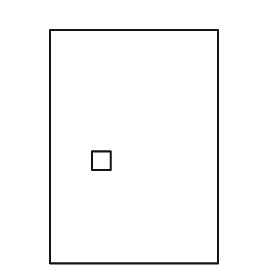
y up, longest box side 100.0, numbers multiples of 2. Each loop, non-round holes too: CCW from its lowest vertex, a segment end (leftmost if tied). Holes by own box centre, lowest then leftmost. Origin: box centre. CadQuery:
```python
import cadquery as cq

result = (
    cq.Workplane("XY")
    .moveTo(-36.0, -50.0)
    .lineTo(36.0, -50.0)
    .lineTo(36.0, 50.0)
    .lineTo(-36.0, 50.0)
    .close()
    .moveTo(-18.0, -10.0)
    .lineTo(-10.0, -10.0)
    .lineTo(-10.0, -2.0)
    .lineTo(-18.0, -2.0)
    .close()
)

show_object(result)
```